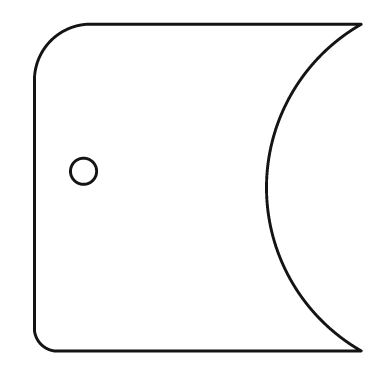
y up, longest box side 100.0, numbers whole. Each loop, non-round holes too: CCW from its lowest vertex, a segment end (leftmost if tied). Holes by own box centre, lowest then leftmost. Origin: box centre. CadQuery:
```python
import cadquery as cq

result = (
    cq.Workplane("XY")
    .moveTo(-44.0, -50.0)
    .lineTo(50.0, -50.0)
    .threePointArc((21.0, 0.0), (50.0, 50.0))
    .lineTo(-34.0, 50.0)
    .threePointArc((-45.0, 45.0), (-50.0, 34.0))
    .lineTo(-50.0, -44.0)
    .threePointArc((-48.0, -48.0), (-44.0, -50.0))
    .close()
    .moveTo(-35.0, 5.0)
    .circle(4.0)
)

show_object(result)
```